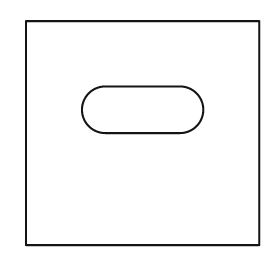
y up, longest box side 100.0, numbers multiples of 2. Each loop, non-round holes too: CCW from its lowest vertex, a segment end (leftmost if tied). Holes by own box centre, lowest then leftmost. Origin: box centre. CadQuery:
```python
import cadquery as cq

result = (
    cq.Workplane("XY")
    .moveTo(-50.0, -48.0)
    .lineTo(50.0, -48.0)
    .lineTo(50.0, 48.0)
    .lineTo(-50.0, 48.0)
    .close()
    .moveTo(-16.0, 0.0)
    .lineTo(16.0, 0.0)
    .threePointArc((26.0, 10.0), (16.0, 20.0))
    .lineTo(-16.0, 20.0)
    .threePointArc((-26.0, 10.0), (-16.0, 0.0))
    .close()
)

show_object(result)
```